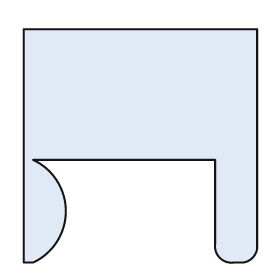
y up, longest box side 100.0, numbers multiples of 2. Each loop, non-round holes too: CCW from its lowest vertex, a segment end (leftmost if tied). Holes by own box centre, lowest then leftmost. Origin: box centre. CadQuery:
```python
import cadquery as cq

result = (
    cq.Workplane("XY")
    .moveTo(-50.0, -50.0)
    .lineTo(-46.0, -50.0)
    .threePointArc((-32.0, -28.0), (-46.0, -6.0))
    .lineTo(32.0, -6.0)
    .lineTo(32.0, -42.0)
    .threePointArc((34.0, -48.0), (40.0, -50.0))
    .lineTo(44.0, -50.0)
    .threePointArc((48.0, -48.0), (50.0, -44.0))
    .lineTo(50.0, 50.0)
    .lineTo(-50.0, 50.0)
    .close()
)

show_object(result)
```